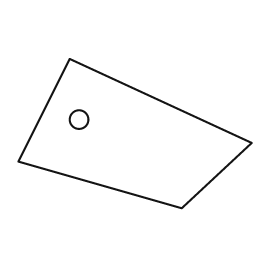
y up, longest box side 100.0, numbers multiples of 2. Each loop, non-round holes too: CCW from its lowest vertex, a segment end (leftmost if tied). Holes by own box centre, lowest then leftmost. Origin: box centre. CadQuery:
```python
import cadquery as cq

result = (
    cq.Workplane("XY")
    .moveTo(20.0, -32.0)
    .lineTo(50.0, -4.0)
    .lineTo(-28.0, 32.0)
    .lineTo(-50.0, -12.0)
    .close()
    .moveTo(-24.0, 6.0)
    .circle(4.0)
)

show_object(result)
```